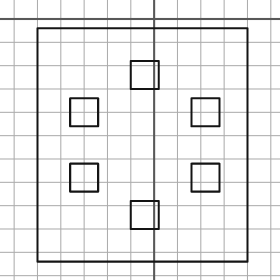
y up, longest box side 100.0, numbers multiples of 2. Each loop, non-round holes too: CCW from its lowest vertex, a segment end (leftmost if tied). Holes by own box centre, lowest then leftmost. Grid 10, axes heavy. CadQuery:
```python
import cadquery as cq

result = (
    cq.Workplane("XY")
    .moveTo(-50.0, -104.0)
    .lineTo(40.0, -104.0)
    .lineTo(40.0, -4.0)
    .lineTo(-50.0, -4.0)
    .close()
    .moveTo(-10.0, -90.0)
    .lineTo(2.0, -90.0)
    .lineTo(2.0, -78.0)
    .lineTo(-10.0, -78.0)
    .close()
    .moveTo(-36.0, -74.0)
    .lineTo(-24.0, -74.0)
    .lineTo(-24.0, -62.0)
    .lineTo(-36.0, -62.0)
    .close()
    .moveTo(16.0, -74.0)
    .lineTo(28.0, -74.0)
    .lineTo(28.0, -62.0)
    .lineTo(16.0, -62.0)
    .close()
    .moveTo(-36.0, -46.0)
    .lineTo(-24.0, -46.0)
    .lineTo(-24.0, -34.0)
    .lineTo(-36.0, -34.0)
    .close()
    .moveTo(16.0, -46.0)
    .lineTo(28.0, -46.0)
    .lineTo(28.0, -34.0)
    .lineTo(16.0, -34.0)
    .close()
    .moveTo(-10.0, -30.0)
    .lineTo(2.0, -30.0)
    .lineTo(2.0, -18.0)
    .lineTo(-10.0, -18.0)
    .close()
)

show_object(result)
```